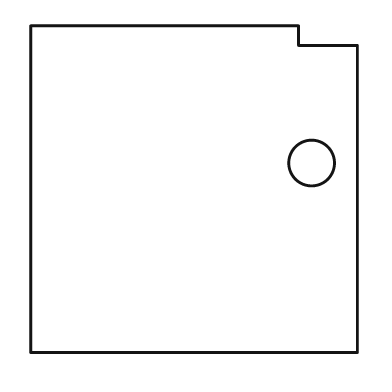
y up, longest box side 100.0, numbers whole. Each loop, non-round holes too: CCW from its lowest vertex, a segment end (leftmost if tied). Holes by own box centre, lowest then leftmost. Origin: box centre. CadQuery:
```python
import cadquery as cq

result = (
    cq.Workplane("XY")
    .moveTo(-50.0, -50.0)
    .lineTo(50.0, -50.0)
    .lineTo(50.0, 44.0)
    .lineTo(32.0, 44.0)
    .lineTo(32.0, 50.0)
    .lineTo(-50.0, 50.0)
    .close()
    .moveTo(36.0, 8.0)
    .circle(7.0)
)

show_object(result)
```